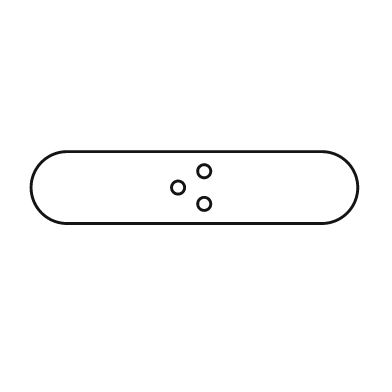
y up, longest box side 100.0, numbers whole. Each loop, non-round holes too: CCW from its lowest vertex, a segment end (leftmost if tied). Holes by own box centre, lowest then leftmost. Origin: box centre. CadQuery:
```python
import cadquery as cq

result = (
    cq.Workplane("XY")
    .moveTo(-39.0, -11.0)
    .lineTo(39.0, -11.0)
    .threePointArc((50.0, 0.0), (39.0, 11.0))
    .lineTo(-39.0, 11.0)
    .threePointArc((-50.0, 0.0), (-39.0, -11.0))
    .close()
    .moveTo(3.0, -5.0)
    .circle(2.0)
    .moveTo(-5.0, 0.0)
    .circle(2.0)
    .moveTo(3.0, 5.0)
    .circle(2.0)
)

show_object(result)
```